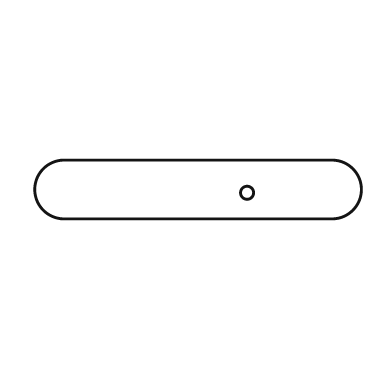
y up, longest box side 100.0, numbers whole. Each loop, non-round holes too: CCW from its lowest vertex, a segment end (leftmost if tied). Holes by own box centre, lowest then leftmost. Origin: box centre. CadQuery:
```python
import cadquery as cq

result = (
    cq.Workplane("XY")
    .moveTo(-41.0, -9.0)
    .lineTo(41.0, -9.0)
    .threePointArc((50.0, 0.0), (41.0, 9.0))
    .lineTo(-41.0, 9.0)
    .threePointArc((-50.0, 0.0), (-41.0, -9.0))
    .close()
    .moveTo(15.0, -1.0)
    .circle(2.0)
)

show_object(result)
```